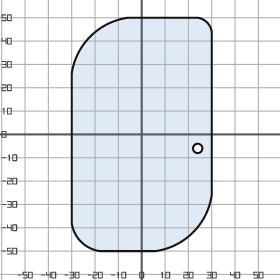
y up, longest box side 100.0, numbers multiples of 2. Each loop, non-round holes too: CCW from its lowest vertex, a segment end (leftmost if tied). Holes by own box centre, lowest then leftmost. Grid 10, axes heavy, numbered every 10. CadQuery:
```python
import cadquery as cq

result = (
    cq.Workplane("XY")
    .moveTo(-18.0, -50.0)
    .lineTo(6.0, -50.0)
    .threePointArc((22.0, -42.0), (30.0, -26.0))
    .lineTo(30.0, 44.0)
    .threePointArc((28.0, 48.0), (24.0, 50.0))
    .lineTo(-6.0, 50.0)
    .threePointArc((-22.0, 42.0), (-30.0, 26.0))
    .lineTo(-30.0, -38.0)
    .threePointArc((-26.0, -46.0), (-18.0, -50.0))
    .close()
    .moveTo(24.0, -6.0)
    .circle(2.0)
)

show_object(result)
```